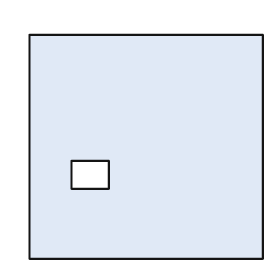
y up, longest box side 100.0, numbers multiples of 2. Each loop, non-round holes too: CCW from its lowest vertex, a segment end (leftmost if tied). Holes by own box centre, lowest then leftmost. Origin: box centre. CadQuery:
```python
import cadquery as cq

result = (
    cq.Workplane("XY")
    .moveTo(-50.0, -48.0)
    .lineTo(50.0, -48.0)
    .lineTo(50.0, 48.0)
    .lineTo(-50.0, 48.0)
    .close()
    .moveTo(-32.0, -18.0)
    .lineTo(-16.0, -18.0)
    .lineTo(-16.0, -6.0)
    .lineTo(-32.0, -6.0)
    .close()
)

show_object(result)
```